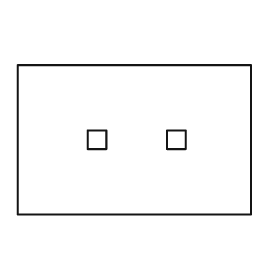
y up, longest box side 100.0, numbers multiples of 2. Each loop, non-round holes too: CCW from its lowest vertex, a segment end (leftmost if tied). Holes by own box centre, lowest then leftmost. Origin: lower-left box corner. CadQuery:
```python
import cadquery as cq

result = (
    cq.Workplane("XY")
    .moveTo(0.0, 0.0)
    .lineTo(100.0, 0.0)
    .lineTo(100.0, 64.0)
    .lineTo(0.0, 64.0)
    .close()
    .moveTo(30.0, 28.0)
    .lineTo(38.0, 28.0)
    .lineTo(38.0, 36.0)
    .lineTo(30.0, 36.0)
    .close()
    .moveTo(64.0, 28.0)
    .lineTo(72.0, 28.0)
    .lineTo(72.0, 36.0)
    .lineTo(64.0, 36.0)
    .close()
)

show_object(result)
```